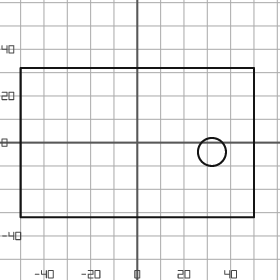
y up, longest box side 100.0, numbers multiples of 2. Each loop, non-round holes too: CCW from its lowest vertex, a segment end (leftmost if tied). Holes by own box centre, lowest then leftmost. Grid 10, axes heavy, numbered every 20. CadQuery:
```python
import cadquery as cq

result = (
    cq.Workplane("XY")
    .moveTo(-50.0, -32.0)
    .lineTo(50.0, -32.0)
    .lineTo(50.0, 32.0)
    .lineTo(-50.0, 32.0)
    .close()
    .moveTo(32.0, -4.0)
    .circle(6.0)
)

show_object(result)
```